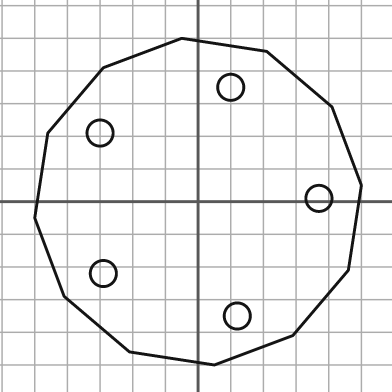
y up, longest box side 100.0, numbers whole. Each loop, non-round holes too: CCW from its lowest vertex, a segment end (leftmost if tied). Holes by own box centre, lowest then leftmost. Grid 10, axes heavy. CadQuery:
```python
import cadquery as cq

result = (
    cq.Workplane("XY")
    .moveTo(5.0, -50.0)
    .lineTo(29.0, -41.0)
    .lineTo(46.0, -21.0)
    .lineTo(50.0, 5.0)
    .lineTo(41.0, 29.0)
    .lineTo(21.0, 46.0)
    .lineTo(-5.0, 50.0)
    .lineTo(-29.0, 41.0)
    .lineTo(-46.0, 21.0)
    .lineTo(-50.0, -5.0)
    .lineTo(-41.0, -29.0)
    .lineTo(-21.0, -46.0)
    .close()
    .moveTo(12.0, -35.0)
    .circle(4.0)
    .moveTo(-29.0, -22.0)
    .circle(4.0)
    .moveTo(37.0, 1.0)
    .circle(4.0)
    .moveTo(-30.0, 21.0)
    .circle(4.0)
    .moveTo(10.0, 35.0)
    .circle(4.0)
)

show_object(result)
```